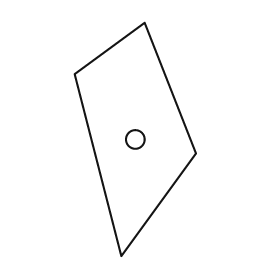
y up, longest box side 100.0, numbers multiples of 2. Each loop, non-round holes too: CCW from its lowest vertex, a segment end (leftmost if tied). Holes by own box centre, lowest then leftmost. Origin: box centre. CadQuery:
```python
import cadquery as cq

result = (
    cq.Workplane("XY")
    .moveTo(-6.0, -50.0)
    .lineTo(26.0, -6.0)
    .lineTo(4.0, 50.0)
    .lineTo(-26.0, 28.0)
    .close()
    .moveTo(0.0, 0.0)
    .circle(4.0)
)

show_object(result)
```